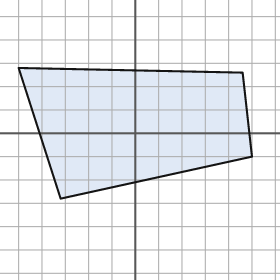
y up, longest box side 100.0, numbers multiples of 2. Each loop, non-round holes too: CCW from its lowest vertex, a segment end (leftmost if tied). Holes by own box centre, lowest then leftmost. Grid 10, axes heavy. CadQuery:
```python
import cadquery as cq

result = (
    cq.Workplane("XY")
    .moveTo(-32.0, -28.0)
    .lineTo(50.0, -10.0)
    .lineTo(46.0, 26.0)
    .lineTo(-50.0, 28.0)
    .close()
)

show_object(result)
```